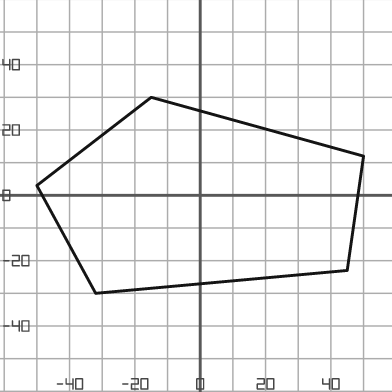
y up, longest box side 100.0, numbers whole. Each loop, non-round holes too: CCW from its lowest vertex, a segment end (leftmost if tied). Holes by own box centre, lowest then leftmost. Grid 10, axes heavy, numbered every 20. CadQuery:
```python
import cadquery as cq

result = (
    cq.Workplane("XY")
    .moveTo(-32.0, -30.0)
    .lineTo(45.0, -23.0)
    .lineTo(50.0, 12.0)
    .lineTo(-15.0, 30.0)
    .lineTo(-50.0, 3.0)
    .close()
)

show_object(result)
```